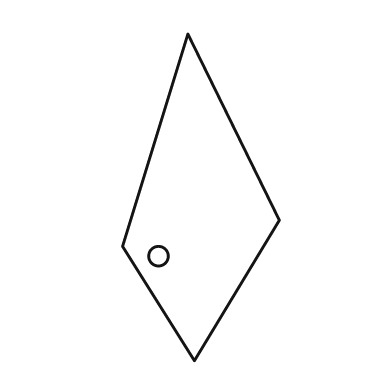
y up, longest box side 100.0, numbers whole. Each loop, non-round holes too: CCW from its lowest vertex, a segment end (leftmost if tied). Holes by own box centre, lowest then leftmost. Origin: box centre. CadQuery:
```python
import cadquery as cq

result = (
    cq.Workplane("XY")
    .moveTo(-2.0, -50.0)
    .lineTo(24.0, -7.0)
    .lineTo(-4.0, 50.0)
    .lineTo(-24.0, -15.0)
    .close()
    .moveTo(-13.0, -18.0)
    .circle(3.0)
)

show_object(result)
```